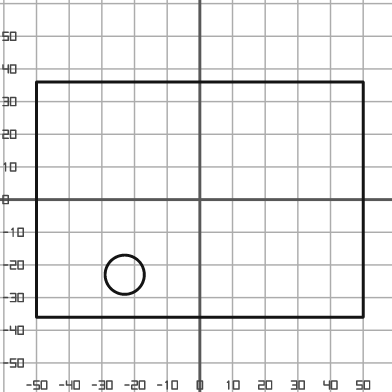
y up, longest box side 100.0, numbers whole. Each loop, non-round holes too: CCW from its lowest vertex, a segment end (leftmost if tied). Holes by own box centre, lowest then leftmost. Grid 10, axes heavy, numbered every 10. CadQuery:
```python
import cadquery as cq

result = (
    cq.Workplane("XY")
    .moveTo(-50.0, -36.0)
    .lineTo(50.0, -36.0)
    .lineTo(50.0, 36.0)
    .lineTo(-50.0, 36.0)
    .close()
    .moveTo(-23.0, -23.0)
    .circle(6.0)
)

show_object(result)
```